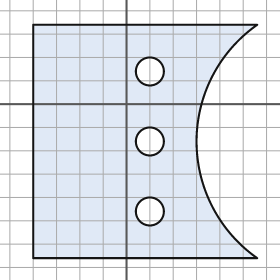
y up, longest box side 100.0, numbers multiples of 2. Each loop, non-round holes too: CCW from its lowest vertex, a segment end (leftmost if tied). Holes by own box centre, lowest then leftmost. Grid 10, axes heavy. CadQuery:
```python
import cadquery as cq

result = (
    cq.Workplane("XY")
    .moveTo(-40.0, -66.0)
    .lineTo(56.0, -66.0)
    .threePointArc((30.0, -16.0), (56.0, 34.0))
    .lineTo(-40.0, 34.0)
    .close()
    .moveTo(10.0, -46.0)
    .circle(6.0)
    .moveTo(10.0, -16.0)
    .circle(6.0)
    .moveTo(10.0, 14.0)
    .circle(6.0)
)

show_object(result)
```